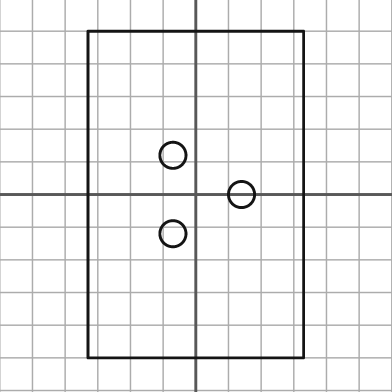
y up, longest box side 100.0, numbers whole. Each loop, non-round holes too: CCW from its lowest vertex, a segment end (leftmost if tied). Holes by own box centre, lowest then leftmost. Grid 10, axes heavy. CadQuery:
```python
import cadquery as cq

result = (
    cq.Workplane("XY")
    .moveTo(-33.0, -50.0)
    .lineTo(33.0, -50.0)
    .lineTo(33.0, 50.0)
    .lineTo(-33.0, 50.0)
    .close()
    .moveTo(-7.0, -12.0)
    .circle(4.0)
    .moveTo(14.0, 0.0)
    .circle(4.0)
    .moveTo(-7.0, 12.0)
    .circle(4.0)
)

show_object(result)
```